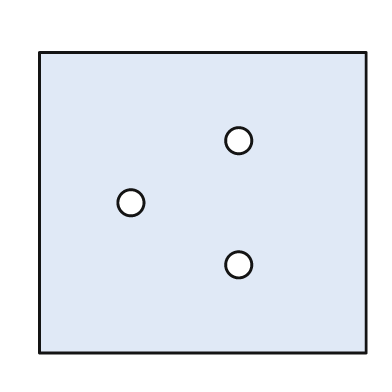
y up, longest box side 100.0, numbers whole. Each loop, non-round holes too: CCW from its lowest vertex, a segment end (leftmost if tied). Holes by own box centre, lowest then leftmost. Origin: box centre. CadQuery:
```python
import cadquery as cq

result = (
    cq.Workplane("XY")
    .moveTo(-50.0, -46.0)
    .lineTo(50.0, -46.0)
    .lineTo(50.0, 46.0)
    .lineTo(-50.0, 46.0)
    .close()
    .moveTo(11.0, -19.0)
    .circle(4.0)
    .moveTo(-22.0, 0.0)
    .circle(4.0)
    .moveTo(11.0, 19.0)
    .circle(4.0)
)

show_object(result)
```